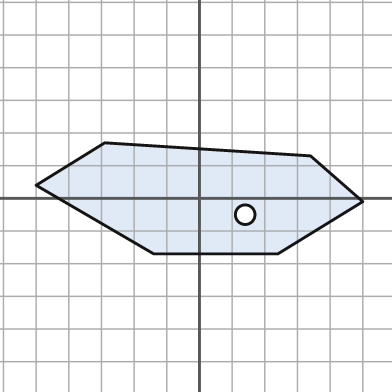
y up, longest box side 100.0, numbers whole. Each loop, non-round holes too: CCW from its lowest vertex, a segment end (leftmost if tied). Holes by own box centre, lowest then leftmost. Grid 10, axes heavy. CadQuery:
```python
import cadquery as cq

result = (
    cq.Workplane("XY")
    .moveTo(-14.0, -17.0)
    .lineTo(24.0, -17.0)
    .lineTo(50.0, -1.0)
    .lineTo(34.0, 13.0)
    .lineTo(-29.0, 17.0)
    .lineTo(-50.0, 4.0)
    .close()
    .moveTo(14.0, -5.0)
    .circle(3.0)
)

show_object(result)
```